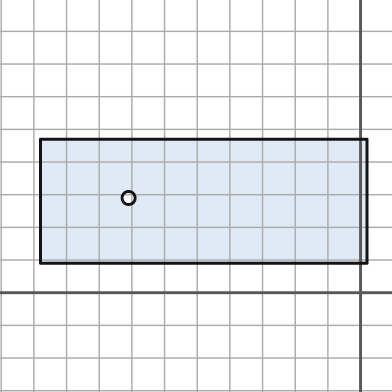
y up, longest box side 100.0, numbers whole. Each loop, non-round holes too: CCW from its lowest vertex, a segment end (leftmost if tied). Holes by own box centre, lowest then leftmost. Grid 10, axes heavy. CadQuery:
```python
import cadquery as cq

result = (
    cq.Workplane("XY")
    .moveTo(-98.0, 9.0)
    .lineTo(2.0, 9.0)
    .lineTo(2.0, 47.0)
    .lineTo(-98.0, 47.0)
    .close()
    .moveTo(-71.0, 29.0)
    .circle(2.0)
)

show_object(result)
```